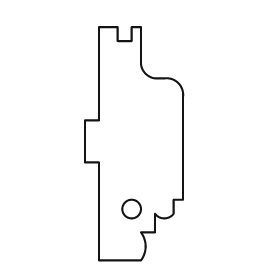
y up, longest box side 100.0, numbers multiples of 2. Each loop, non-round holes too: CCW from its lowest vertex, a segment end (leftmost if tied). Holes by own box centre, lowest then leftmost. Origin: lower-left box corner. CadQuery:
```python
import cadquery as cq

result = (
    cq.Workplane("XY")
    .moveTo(6.0, 0.0)
    .lineTo(24.0, 0.0)
    .threePointArc((26.0, 6.0), (24.0, 12.0))
    .lineTo(30.0, 12.0)
    .lineTo(30.0, 20.0)
    .threePointArc((34.0, 18.0), (38.0, 20.0))
    .lineTo(38.0, 26.0)
    .lineTo(42.0, 26.0)
    .lineTo(42.0, 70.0)
    .threePointArc((40.0, 76.0), (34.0, 78.0))
    .lineTo(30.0, 78.0)
    .threePointArc((26.0, 80.0), (24.0, 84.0))
    .lineTo(24.0, 100.0)
    .lineTo(20.0, 100.0)
    .lineTo(20.0, 94.0)
    .lineTo(14.0, 94.0)
    .lineTo(14.0, 100.0)
    .lineTo(6.0, 100.0)
    .lineTo(6.0, 60.0)
    .lineTo(0.0, 60.0)
    .lineTo(0.0, 42.0)
    .lineTo(6.0, 42.0)
    .close()
    .moveTo(20.0, 22.0)
    .circle(4.0)
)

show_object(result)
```